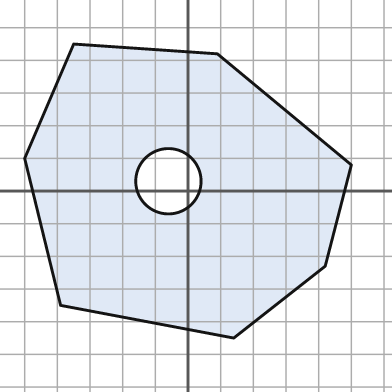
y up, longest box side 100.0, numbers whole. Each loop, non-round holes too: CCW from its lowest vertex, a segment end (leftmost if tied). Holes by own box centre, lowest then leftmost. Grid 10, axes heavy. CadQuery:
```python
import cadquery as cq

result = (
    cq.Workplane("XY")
    .moveTo(14.0, -45.0)
    .lineTo(42.0, -23.0)
    .lineTo(50.0, 8.0)
    .lineTo(9.0, 42.0)
    .lineTo(-35.0, 45.0)
    .lineTo(-50.0, 10.0)
    .lineTo(-39.0, -35.0)
    .close()
    .moveTo(-6.0, 3.0)
    .circle(10.0)
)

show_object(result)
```